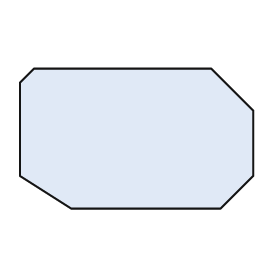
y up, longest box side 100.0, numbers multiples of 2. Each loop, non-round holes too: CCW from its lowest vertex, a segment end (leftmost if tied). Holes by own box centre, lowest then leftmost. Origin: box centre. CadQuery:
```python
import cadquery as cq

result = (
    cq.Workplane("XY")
    .moveTo(-28.0, -30.0)
    .lineTo(36.0, -30.0)
    .lineTo(50.0, -16.0)
    .lineTo(50.0, 12.0)
    .lineTo(32.0, 30.0)
    .lineTo(-44.0, 30.0)
    .lineTo(-50.0, 24.0)
    .lineTo(-50.0, -16.0)
    .close()
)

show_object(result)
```